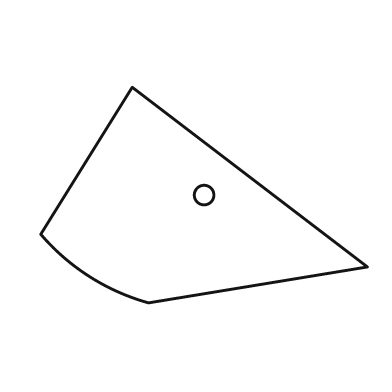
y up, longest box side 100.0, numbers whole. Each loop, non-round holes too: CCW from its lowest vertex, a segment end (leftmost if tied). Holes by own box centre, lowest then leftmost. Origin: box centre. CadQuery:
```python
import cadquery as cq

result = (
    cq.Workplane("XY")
    .moveTo(-17.0, -33.0)
    .lineTo(50.0, -22.0)
    .lineTo(-22.0, 33.0)
    .lineTo(-50.0, -12.0)
    .threePointArc((-35.0, -25.0), (-17.0, -33.0))
    .close()
    .moveTo(0.0, 0.0)
    .circle(3.0)
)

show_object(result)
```